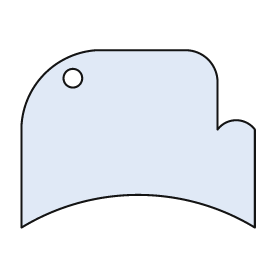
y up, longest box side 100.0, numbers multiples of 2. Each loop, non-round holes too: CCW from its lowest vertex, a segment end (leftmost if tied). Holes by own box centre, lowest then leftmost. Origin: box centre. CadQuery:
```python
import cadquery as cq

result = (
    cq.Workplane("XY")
    .moveTo(-50.0, -38.0)
    .threePointArc((0.0, -24.0), (50.0, -38.0))
    .lineTo(50.0, 4.0)
    .threePointArc((42.0, 8.0), (34.0, 4.0))
    .lineTo(34.0, 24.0)
    .threePointArc((30.0, 34.0), (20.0, 38.0))
    .lineTo(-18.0, 38.0)
    .threePointArc((-40.0, 28.0), (-50.0, 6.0))
    .close()
    .moveTo(-28.0, 26.0)
    .circle(4.0)
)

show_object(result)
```